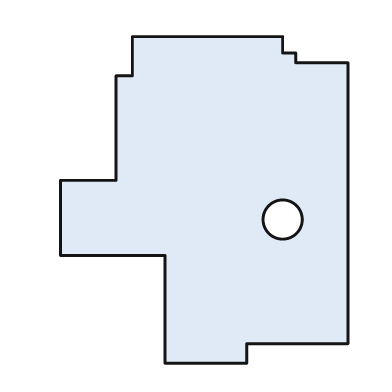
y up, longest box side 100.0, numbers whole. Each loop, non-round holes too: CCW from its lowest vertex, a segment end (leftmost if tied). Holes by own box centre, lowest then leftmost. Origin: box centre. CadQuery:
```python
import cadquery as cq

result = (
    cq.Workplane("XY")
    .moveTo(-12.0, -50.0)
    .lineTo(13.0, -50.0)
    .lineTo(13.0, -44.0)
    .lineTo(44.0, -44.0)
    .lineTo(44.0, 42.0)
    .lineTo(28.0, 42.0)
    .lineTo(28.0, 45.0)
    .lineTo(24.0, 45.0)
    .lineTo(24.0, 50.0)
    .lineTo(-22.0, 50.0)
    .lineTo(-22.0, 38.0)
    .lineTo(-27.0, 38.0)
    .lineTo(-27.0, 6.0)
    .lineTo(-44.0, 6.0)
    .lineTo(-44.0, -17.0)
    .lineTo(-12.0, -17.0)
    .close()
    .moveTo(24.0, -6.0)
    .circle(6.0)
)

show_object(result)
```